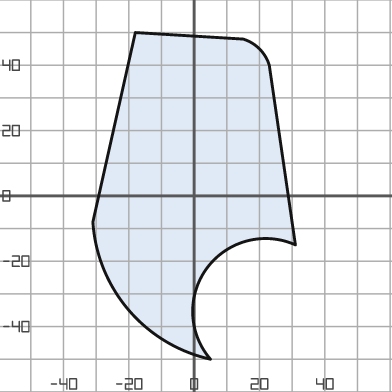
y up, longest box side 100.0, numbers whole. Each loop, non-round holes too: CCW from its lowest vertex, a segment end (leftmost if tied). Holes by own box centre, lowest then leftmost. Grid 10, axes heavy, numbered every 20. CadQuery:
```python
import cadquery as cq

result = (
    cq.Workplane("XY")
    .moveTo(5.0, -50.0)
    .threePointArc((4.0, -22.0), (31.0, -15.0))
    .lineTo(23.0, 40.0)
    .threePointArc((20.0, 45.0), (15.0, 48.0))
    .lineTo(-18.0, 50.0)
    .lineTo(-31.0, -8.0)
    .threePointArc((-20.0, -35.0), (5.0, -50.0))
    .close()
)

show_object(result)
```